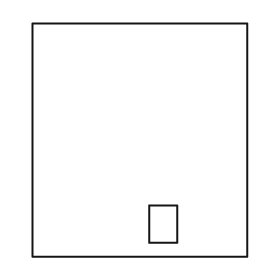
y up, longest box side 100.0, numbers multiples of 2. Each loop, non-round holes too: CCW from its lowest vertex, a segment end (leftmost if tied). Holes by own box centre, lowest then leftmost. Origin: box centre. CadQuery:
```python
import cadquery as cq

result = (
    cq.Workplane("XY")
    .moveTo(-46.0, -50.0)
    .lineTo(46.0, -50.0)
    .lineTo(46.0, 50.0)
    .lineTo(-46.0, 50.0)
    .close()
    .moveTo(4.0, -44.0)
    .lineTo(16.0, -44.0)
    .lineTo(16.0, -28.0)
    .lineTo(4.0, -28.0)
    .close()
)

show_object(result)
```